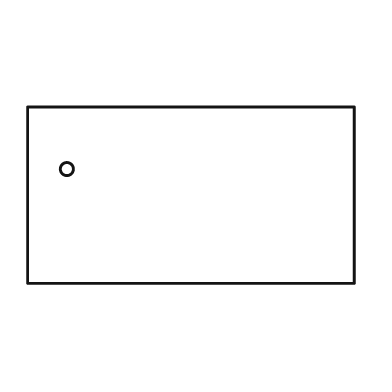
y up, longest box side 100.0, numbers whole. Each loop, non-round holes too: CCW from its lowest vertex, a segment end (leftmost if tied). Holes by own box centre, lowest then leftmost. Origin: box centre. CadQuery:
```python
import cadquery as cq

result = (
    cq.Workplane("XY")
    .moveTo(-50.0, -27.0)
    .lineTo(50.0, -27.0)
    .lineTo(50.0, 27.0)
    .lineTo(-50.0, 27.0)
    .close()
    .moveTo(-38.0, 8.0)
    .circle(2.0)
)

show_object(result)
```